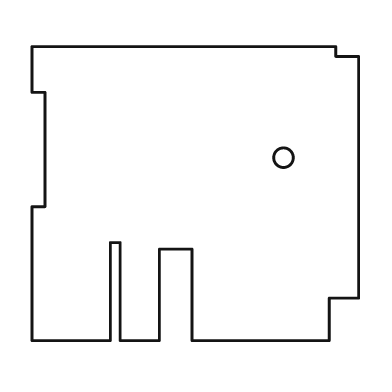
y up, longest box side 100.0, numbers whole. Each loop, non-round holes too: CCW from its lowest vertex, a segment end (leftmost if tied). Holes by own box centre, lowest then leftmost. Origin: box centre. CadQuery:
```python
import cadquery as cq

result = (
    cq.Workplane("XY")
    .moveTo(-50.0, -45.0)
    .lineTo(-26.0, -45.0)
    .lineTo(-26.0, -15.0)
    .lineTo(-23.0, -15.0)
    .lineTo(-23.0, -45.0)
    .lineTo(-11.0, -45.0)
    .lineTo(-11.0, -17.0)
    .lineTo(-1.0, -17.0)
    .lineTo(-1.0, -45.0)
    .lineTo(41.0, -45.0)
    .lineTo(41.0, -32.0)
    .lineTo(50.0, -32.0)
    .lineTo(50.0, 42.0)
    .lineTo(43.0, 42.0)
    .lineTo(43.0, 45.0)
    .lineTo(-50.0, 45.0)
    .lineTo(-50.0, 31.0)
    .lineTo(-46.0, 31.0)
    .lineTo(-46.0, -4.0)
    .lineTo(-50.0, -4.0)
    .close()
    .moveTo(27.0, 11.0)
    .circle(3.0)
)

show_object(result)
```